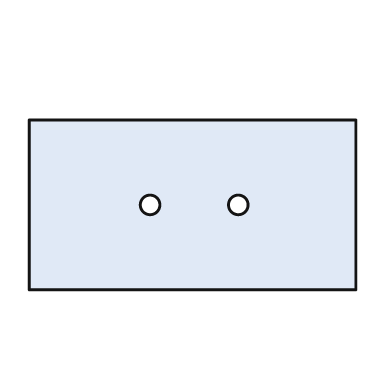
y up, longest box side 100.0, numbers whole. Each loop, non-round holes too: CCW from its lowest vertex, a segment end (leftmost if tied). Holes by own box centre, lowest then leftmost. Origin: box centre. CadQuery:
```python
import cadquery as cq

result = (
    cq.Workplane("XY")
    .moveTo(-50.0, -26.0)
    .lineTo(50.0, -26.0)
    .lineTo(50.0, 26.0)
    .lineTo(-50.0, 26.0)
    .close()
    .moveTo(-13.0, 0.0)
    .circle(3.0)
    .moveTo(14.0, 0.0)
    .circle(3.0)
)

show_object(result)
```